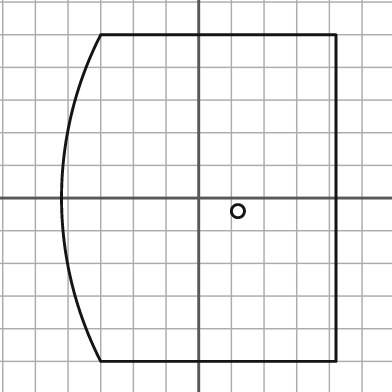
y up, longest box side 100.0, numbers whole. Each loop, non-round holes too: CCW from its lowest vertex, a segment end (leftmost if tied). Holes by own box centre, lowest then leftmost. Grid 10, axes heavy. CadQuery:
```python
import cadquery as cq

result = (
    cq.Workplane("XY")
    .moveTo(-30.0, -50.0)
    .lineTo(42.0, -50.0)
    .lineTo(42.0, 50.0)
    .lineTo(-30.0, 50.0)
    .threePointArc((-42.0, 0.0), (-30.0, -50.0))
    .close()
    .moveTo(12.0, -4.0)
    .circle(2.0)
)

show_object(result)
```